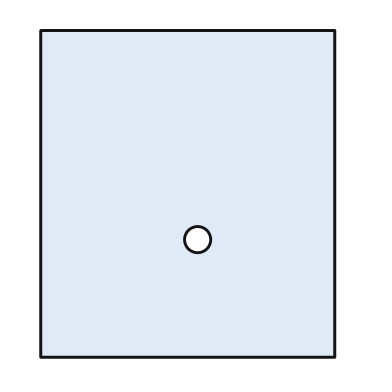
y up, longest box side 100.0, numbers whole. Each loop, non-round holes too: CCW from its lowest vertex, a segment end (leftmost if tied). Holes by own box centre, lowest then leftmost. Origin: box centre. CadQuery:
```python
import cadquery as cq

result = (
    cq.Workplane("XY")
    .moveTo(-45.0, -50.0)
    .lineTo(45.0, -50.0)
    .lineTo(45.0, 50.0)
    .lineTo(-45.0, 50.0)
    .close()
    .moveTo(3.0, -14.0)
    .circle(4.0)
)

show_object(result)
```